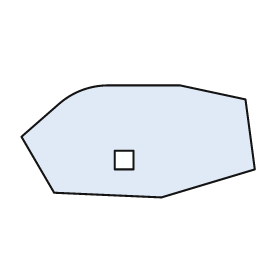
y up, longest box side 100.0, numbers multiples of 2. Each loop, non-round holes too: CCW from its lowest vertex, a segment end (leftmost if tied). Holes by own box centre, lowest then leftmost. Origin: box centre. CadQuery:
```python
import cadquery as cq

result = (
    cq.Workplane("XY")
    .moveTo(10.0, -24.0)
    .lineTo(50.0, -12.0)
    .lineTo(46.0, 18.0)
    .lineTo(18.0, 24.0)
    .lineTo(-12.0, 24.0)
    .threePointArc((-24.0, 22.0), (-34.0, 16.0))
    .lineTo(-50.0, 2.0)
    .lineTo(-36.0, -22.0)
    .close()
    .moveTo(-10.0, -12.0)
    .lineTo(-2.0, -12.0)
    .lineTo(-2.0, -4.0)
    .lineTo(-10.0, -4.0)
    .close()
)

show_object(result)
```